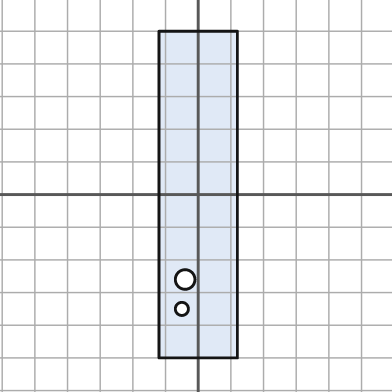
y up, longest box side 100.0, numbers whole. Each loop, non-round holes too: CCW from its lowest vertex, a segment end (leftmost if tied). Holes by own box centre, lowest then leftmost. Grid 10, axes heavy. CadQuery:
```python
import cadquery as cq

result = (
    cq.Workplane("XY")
    .moveTo(-12.0, -50.0)
    .lineTo(12.0, -50.0)
    .lineTo(12.0, 50.0)
    .lineTo(-12.0, 50.0)
    .close()
    .moveTo(-5.0, -35.0)
    .circle(2.0)
    .moveTo(-4.0, -26.0)
    .circle(3.0)
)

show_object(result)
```